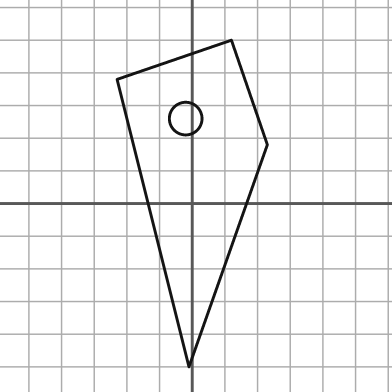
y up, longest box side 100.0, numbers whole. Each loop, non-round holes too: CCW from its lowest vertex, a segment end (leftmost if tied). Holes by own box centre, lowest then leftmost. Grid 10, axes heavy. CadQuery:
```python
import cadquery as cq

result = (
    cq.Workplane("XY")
    .moveTo(-1.0, -50.0)
    .lineTo(23.0, 18.0)
    .lineTo(12.0, 50.0)
    .lineTo(-23.0, 38.0)
    .close()
    .moveTo(-2.0, 26.0)
    .circle(5.0)
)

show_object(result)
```